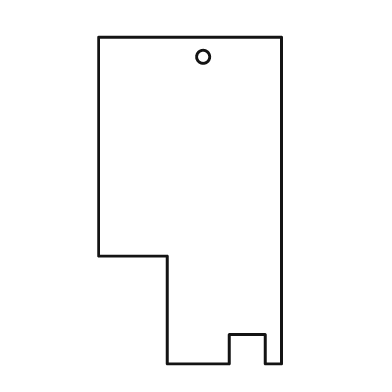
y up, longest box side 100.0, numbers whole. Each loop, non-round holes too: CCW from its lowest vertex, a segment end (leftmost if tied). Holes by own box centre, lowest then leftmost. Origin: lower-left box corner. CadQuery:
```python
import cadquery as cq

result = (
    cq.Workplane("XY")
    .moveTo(21.0, 0.0)
    .lineTo(40.0, 0.0)
    .lineTo(40.0, 9.0)
    .lineTo(51.0, 9.0)
    .lineTo(51.0, 0.0)
    .lineTo(56.0, 0.0)
    .lineTo(56.0, 100.0)
    .lineTo(0.0, 100.0)
    .lineTo(0.0, 33.0)
    .lineTo(21.0, 33.0)
    .close()
    .moveTo(32.0, 94.0)
    .circle(2.0)
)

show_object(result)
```